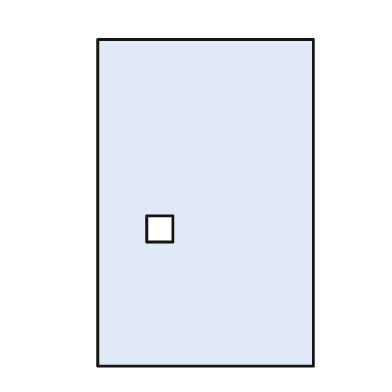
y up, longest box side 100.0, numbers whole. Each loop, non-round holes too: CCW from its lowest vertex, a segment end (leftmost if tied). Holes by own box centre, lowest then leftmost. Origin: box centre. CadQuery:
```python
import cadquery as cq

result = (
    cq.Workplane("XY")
    .moveTo(-33.0, -50.0)
    .lineTo(33.0, -50.0)
    .lineTo(33.0, 50.0)
    .lineTo(-33.0, 50.0)
    .close()
    .moveTo(-18.0, -12.0)
    .lineTo(-10.0, -12.0)
    .lineTo(-10.0, -4.0)
    .lineTo(-18.0, -4.0)
    .close()
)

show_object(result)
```